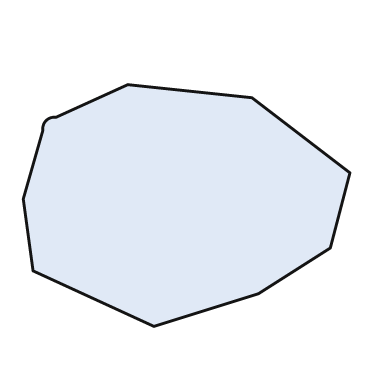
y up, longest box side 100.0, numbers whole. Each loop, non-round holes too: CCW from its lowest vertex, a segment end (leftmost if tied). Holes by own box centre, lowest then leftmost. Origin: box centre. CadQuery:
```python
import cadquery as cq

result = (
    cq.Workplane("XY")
    .moveTo(-10.0, -37.0)
    .lineTo(22.0, -27.0)
    .lineTo(44.0, -13.0)
    .lineTo(50.0, 10.0)
    .lineTo(20.0, 33.0)
    .lineTo(-18.0, 37.0)
    .lineTo(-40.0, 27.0)
    .threePointArc((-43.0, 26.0), (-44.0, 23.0))
    .lineTo(-50.0, 2.0)
    .lineTo(-47.0, -20.0)
    .close()
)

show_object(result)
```